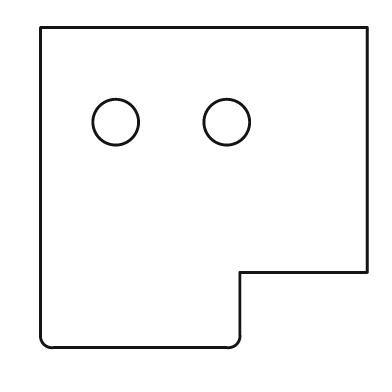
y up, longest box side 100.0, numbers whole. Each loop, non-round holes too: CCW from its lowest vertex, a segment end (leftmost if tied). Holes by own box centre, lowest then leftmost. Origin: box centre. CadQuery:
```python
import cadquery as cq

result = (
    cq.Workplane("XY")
    .moveTo(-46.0, -49.0)
    .lineTo(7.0, -49.0)
    .threePointArc((10.0, -48.0), (11.0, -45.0))
    .lineTo(11.0, -26.0)
    .lineTo(50.0, -26.0)
    .lineTo(50.0, 49.0)
    .lineTo(-50.0, 49.0)
    .lineTo(-50.0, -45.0)
    .threePointArc((-49.0, -48.0), (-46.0, -49.0))
    .close()
    .moveTo(-27.0, 20.0)
    .circle(7.0)
    .moveTo(7.0, 20.0)
    .circle(7.0)
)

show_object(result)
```